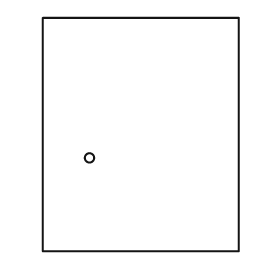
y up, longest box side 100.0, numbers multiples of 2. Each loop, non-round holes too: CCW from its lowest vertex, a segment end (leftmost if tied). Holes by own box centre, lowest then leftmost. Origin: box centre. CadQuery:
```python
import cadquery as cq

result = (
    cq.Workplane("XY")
    .moveTo(-42.0, -50.0)
    .lineTo(42.0, -50.0)
    .lineTo(42.0, 50.0)
    .lineTo(-42.0, 50.0)
    .close()
    .moveTo(-22.0, -10.0)
    .circle(2.0)
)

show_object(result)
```